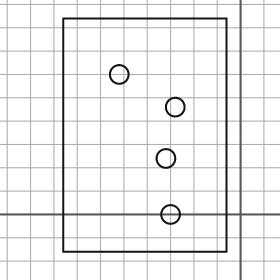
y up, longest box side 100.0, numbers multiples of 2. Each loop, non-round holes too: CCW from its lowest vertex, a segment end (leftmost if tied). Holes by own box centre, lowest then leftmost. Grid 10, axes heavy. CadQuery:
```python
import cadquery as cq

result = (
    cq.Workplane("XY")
    .moveTo(-76.0, -16.0)
    .lineTo(-6.0, -16.0)
    .lineTo(-6.0, 84.0)
    .lineTo(-76.0, 84.0)
    .close()
    .moveTo(-30.0, 0.0)
    .circle(4.0)
    .moveTo(-32.0, 24.0)
    .circle(4.0)
    .moveTo(-28.0, 46.0)
    .circle(4.0)
    .moveTo(-52.0, 60.0)
    .circle(4.0)
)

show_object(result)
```